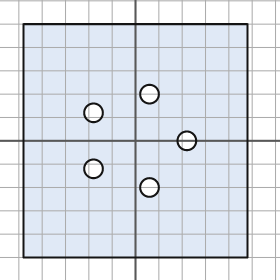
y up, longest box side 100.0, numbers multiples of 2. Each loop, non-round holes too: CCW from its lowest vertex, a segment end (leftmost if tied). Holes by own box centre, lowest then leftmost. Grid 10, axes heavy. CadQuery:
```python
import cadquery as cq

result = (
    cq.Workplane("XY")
    .moveTo(-48.0, -50.0)
    .lineTo(48.0, -50.0)
    .lineTo(48.0, 50.0)
    .lineTo(-48.0, 50.0)
    .close()
    .moveTo(6.0, -20.0)
    .circle(4.0)
    .moveTo(-18.0, -12.0)
    .circle(4.0)
    .moveTo(22.0, 0.0)
    .circle(4.0)
    .moveTo(-18.0, 12.0)
    .circle(4.0)
    .moveTo(6.0, 20.0)
    .circle(4.0)
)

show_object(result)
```